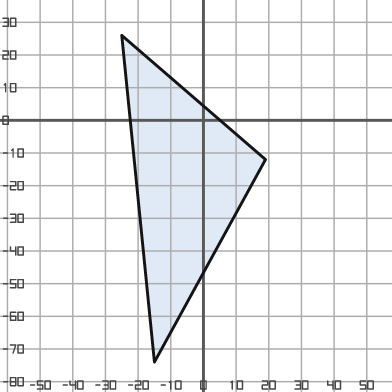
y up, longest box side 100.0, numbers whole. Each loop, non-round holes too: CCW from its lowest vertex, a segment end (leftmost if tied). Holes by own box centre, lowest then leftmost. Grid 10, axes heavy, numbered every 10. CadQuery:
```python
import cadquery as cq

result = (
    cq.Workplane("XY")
    .moveTo(-15.0, -74.0)
    .lineTo(19.0, -12.0)
    .lineTo(-25.0, 26.0)
    .close()
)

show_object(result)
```